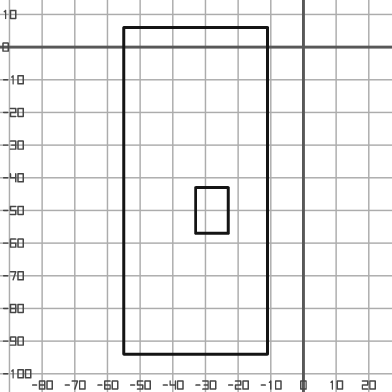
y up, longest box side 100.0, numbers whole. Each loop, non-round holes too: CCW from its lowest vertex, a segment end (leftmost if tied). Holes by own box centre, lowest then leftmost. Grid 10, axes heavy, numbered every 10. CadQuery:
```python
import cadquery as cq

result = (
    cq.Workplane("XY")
    .moveTo(-55.0, -94.0)
    .lineTo(-11.0, -94.0)
    .lineTo(-11.0, 6.0)
    .lineTo(-55.0, 6.0)
    .close()
    .moveTo(-33.0, -57.0)
    .lineTo(-23.0, -57.0)
    .lineTo(-23.0, -43.0)
    .lineTo(-33.0, -43.0)
    .close()
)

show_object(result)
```